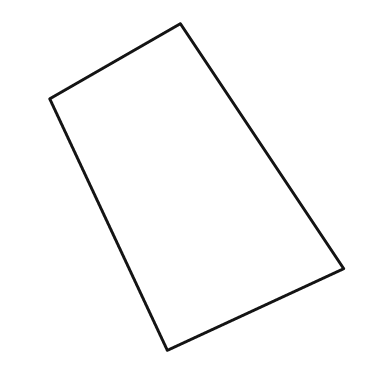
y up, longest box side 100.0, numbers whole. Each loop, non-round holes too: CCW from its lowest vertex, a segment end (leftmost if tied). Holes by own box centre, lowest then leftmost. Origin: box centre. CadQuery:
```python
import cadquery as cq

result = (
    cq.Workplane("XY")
    .moveTo(-9.0, -50.0)
    .lineTo(45.0, -25.0)
    .lineTo(-5.0, 50.0)
    .lineTo(-45.0, 27.0)
    .close()
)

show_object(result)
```